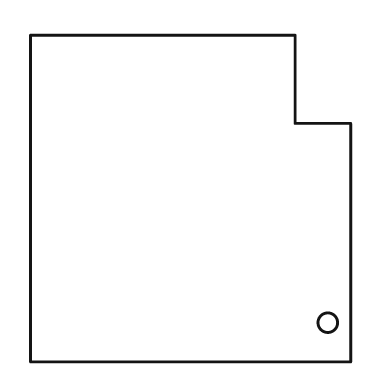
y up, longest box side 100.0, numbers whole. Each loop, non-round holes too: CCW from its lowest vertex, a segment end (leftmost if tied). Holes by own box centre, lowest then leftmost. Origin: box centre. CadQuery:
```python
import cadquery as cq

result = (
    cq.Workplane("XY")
    .moveTo(-49.0, -50.0)
    .lineTo(49.0, -50.0)
    .lineTo(49.0, 23.0)
    .lineTo(32.0, 23.0)
    .lineTo(32.0, 50.0)
    .lineTo(-49.0, 50.0)
    .close()
    .moveTo(42.0, -38.0)
    .circle(3.0)
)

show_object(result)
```